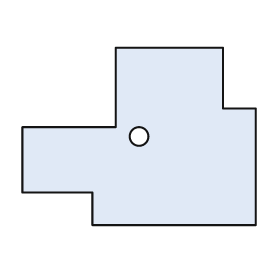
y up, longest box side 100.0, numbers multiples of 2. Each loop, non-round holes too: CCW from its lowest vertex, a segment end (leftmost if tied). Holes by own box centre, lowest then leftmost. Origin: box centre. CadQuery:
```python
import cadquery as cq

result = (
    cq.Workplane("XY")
    .moveTo(-20.0, -38.0)
    .lineTo(50.0, -38.0)
    .lineTo(50.0, 12.0)
    .lineTo(36.0, 12.0)
    .lineTo(36.0, 38.0)
    .lineTo(-10.0, 38.0)
    .lineTo(-10.0, 4.0)
    .lineTo(-50.0, 4.0)
    .lineTo(-50.0, -24.0)
    .lineTo(-20.0, -24.0)
    .close()
    .moveTo(0.0, 0.0)
    .circle(4.0)
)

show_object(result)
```